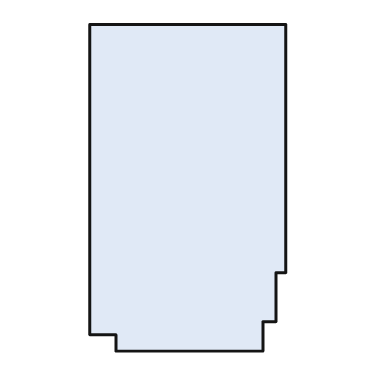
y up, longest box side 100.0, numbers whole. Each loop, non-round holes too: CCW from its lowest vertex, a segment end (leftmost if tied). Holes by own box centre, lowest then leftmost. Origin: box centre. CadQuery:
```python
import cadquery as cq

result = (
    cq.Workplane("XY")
    .moveTo(-22.0, -50.0)
    .lineTo(23.0, -50.0)
    .lineTo(23.0, -41.0)
    .lineTo(27.0, -41.0)
    .lineTo(27.0, -26.0)
    .lineTo(30.0, -26.0)
    .lineTo(30.0, 50.0)
    .lineTo(-30.0, 50.0)
    .lineTo(-30.0, -45.0)
    .lineTo(-22.0, -45.0)
    .close()
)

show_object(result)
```